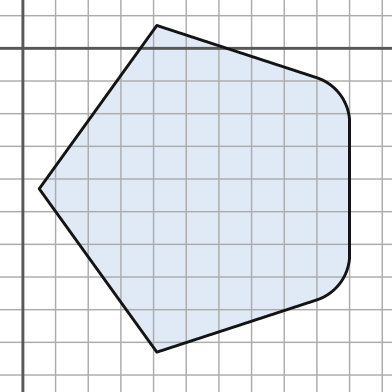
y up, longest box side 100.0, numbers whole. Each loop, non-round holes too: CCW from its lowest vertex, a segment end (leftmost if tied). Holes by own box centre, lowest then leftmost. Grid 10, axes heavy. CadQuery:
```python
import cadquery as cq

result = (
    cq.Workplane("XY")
    .moveTo(41.0, -93.0)
    .lineTo(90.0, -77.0)
    .threePointArc((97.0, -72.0), (100.0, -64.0))
    .lineTo(100.0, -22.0)
    .threePointArc((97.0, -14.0), (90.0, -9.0))
    .lineTo(41.0, 7.0)
    .lineTo(5.0, -43.0)
    .close()
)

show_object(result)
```